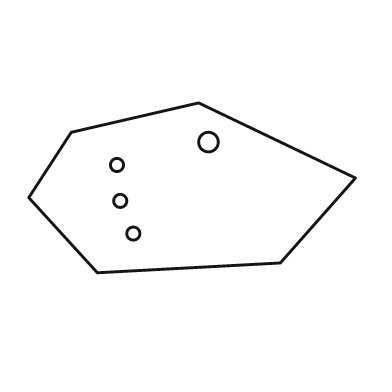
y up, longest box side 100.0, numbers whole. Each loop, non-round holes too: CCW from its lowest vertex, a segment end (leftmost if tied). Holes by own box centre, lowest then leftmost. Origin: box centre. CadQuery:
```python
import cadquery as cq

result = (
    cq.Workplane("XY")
    .moveTo(-29.0, -26.0)
    .lineTo(27.0, -23.0)
    .lineTo(50.0, 3.0)
    .lineTo(2.0, 26.0)
    .lineTo(-37.0, 17.0)
    .lineTo(-50.0, -3.0)
    .close()
    .moveTo(-18.0, -14.0)
    .circle(2.0)
    .moveTo(-22.0, -4.0)
    .circle(2.0)
    .moveTo(-23.0, 7.0)
    .circle(2.0)
    .moveTo(5.0, 14.0)
    .circle(3.0)
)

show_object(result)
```